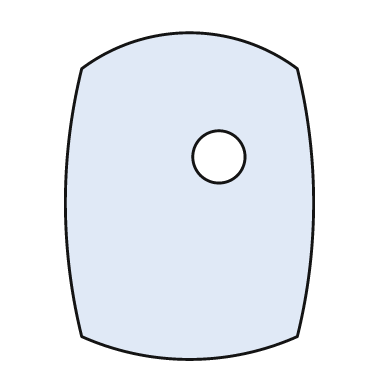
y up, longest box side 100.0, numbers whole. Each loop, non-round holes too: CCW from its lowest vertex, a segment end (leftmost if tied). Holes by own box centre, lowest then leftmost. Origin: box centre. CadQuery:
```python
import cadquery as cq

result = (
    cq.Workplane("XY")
    .moveTo(-33.0, -43.0)
    .threePointArc((0.0, -50.0), (33.0, -43.0))
    .threePointArc((38.0, -2.0), (33.0, 39.0))
    .threePointArc((0.0, 50.0), (-33.0, 39.0))
    .threePointArc((-38.0, -2.0), (-33.0, -43.0))
    .close()
    .moveTo(9.0, 12.0)
    .circle(8.0)
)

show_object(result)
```